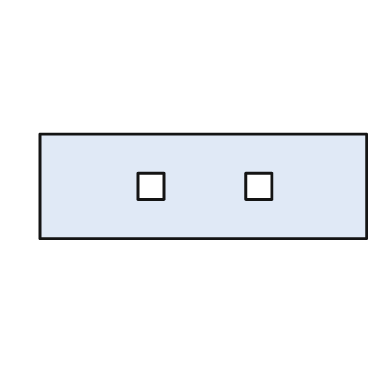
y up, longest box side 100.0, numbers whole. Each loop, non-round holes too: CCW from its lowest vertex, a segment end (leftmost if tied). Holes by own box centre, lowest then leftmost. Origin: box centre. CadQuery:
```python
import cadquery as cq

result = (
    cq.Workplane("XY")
    .moveTo(-50.0, -16.0)
    .lineTo(50.0, -16.0)
    .lineTo(50.0, 16.0)
    .lineTo(-50.0, 16.0)
    .close()
    .moveTo(-20.0, -4.0)
    .lineTo(-12.0, -4.0)
    .lineTo(-12.0, 4.0)
    .lineTo(-20.0, 4.0)
    .close()
    .moveTo(13.0, -4.0)
    .lineTo(21.0, -4.0)
    .lineTo(21.0, 4.0)
    .lineTo(13.0, 4.0)
    .close()
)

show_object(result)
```